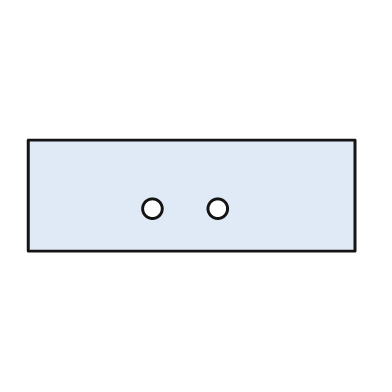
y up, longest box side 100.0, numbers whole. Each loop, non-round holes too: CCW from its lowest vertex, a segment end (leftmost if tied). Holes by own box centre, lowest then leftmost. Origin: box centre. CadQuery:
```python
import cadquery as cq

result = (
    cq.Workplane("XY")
    .moveTo(-50.0, -17.0)
    .lineTo(50.0, -17.0)
    .lineTo(50.0, 17.0)
    .lineTo(-50.0, 17.0)
    .close()
    .moveTo(-12.0, -4.0)
    .circle(3.0)
    .moveTo(8.0, -4.0)
    .circle(3.0)
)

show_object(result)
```